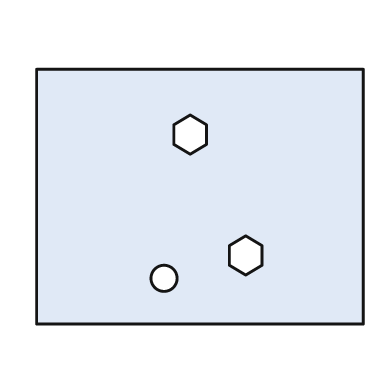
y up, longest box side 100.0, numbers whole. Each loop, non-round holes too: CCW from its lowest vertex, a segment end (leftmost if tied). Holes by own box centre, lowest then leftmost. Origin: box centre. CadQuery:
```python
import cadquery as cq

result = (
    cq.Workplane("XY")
    .moveTo(-50.0, -39.0)
    .lineTo(50.0, -39.0)
    .lineTo(50.0, 39.0)
    .lineTo(-50.0, 39.0)
    .close()
    .moveTo(-11.0, -25.0)
    .circle(4.0)
    .moveTo(14.0, -24.0)
    .lineTo(19.0, -21.0)
    .lineTo(19.0, -15.0)
    .lineTo(14.0, -12.0)
    .lineTo(9.0, -15.0)
    .lineTo(9.0, -21.0)
    .close()
    .moveTo(-3.0, 13.0)
    .lineTo(2.0, 16.0)
    .lineTo(2.0, 22.0)
    .lineTo(-3.0, 25.0)
    .lineTo(-8.0, 22.0)
    .lineTo(-8.0, 16.0)
    .close()
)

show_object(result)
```